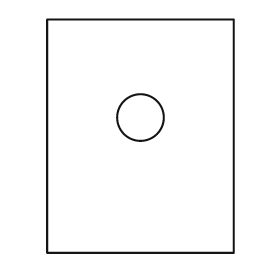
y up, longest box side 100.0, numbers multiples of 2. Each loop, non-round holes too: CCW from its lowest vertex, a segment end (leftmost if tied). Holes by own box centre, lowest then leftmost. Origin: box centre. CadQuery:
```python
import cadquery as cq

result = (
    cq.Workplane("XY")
    .moveTo(-40.0, -50.0)
    .lineTo(40.0, -50.0)
    .lineTo(40.0, 50.0)
    .lineTo(-40.0, 50.0)
    .close()
    .moveTo(0.0, 8.0)
    .circle(10.0)
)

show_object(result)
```